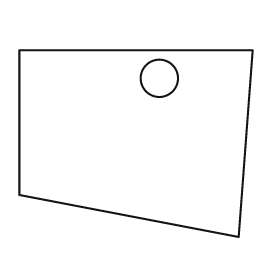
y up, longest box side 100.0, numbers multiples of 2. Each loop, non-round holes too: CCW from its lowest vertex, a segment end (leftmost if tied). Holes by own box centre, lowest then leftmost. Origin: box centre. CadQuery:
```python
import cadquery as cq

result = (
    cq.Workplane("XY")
    .moveTo(44.0, -40.0)
    .lineTo(50.0, 40.0)
    .lineTo(-50.0, 40.0)
    .lineTo(-50.0, -22.0)
    .close()
    .moveTo(10.0, 28.0)
    .circle(8.0)
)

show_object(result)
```